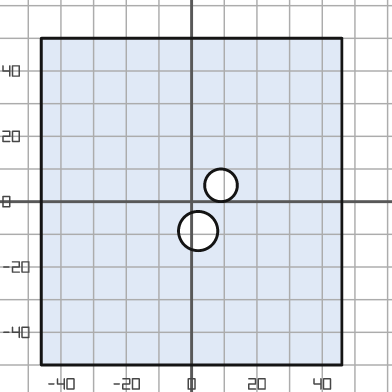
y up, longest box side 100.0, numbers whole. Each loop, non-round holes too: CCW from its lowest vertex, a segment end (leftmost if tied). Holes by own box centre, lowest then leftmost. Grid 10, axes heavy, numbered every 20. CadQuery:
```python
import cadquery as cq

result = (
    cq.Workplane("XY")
    .moveTo(-46.0, -50.0)
    .lineTo(46.0, -50.0)
    .lineTo(46.0, 50.0)
    .lineTo(-46.0, 50.0)
    .close()
    .moveTo(2.0, -9.0)
    .circle(6.0)
    .moveTo(9.0, 5.0)
    .circle(5.0)
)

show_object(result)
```